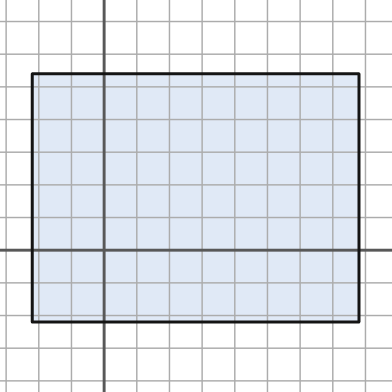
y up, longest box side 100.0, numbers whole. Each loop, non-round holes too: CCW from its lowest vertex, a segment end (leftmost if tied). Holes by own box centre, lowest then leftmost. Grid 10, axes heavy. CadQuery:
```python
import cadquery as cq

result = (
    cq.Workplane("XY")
    .moveTo(-22.0, -22.0)
    .lineTo(78.0, -22.0)
    .lineTo(78.0, 54.0)
    .lineTo(-22.0, 54.0)
    .close()
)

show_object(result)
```